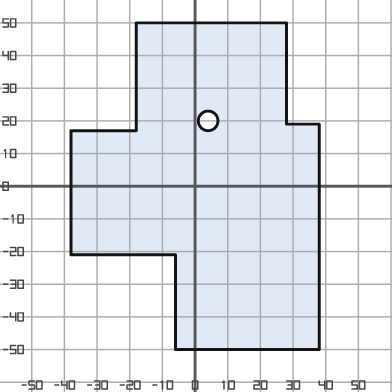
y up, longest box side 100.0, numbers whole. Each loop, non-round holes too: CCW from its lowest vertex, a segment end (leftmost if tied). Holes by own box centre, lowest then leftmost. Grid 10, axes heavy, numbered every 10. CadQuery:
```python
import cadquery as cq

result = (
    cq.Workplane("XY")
    .moveTo(-6.0, -50.0)
    .lineTo(38.0, -50.0)
    .lineTo(38.0, 19.0)
    .lineTo(28.0, 19.0)
    .lineTo(28.0, 50.0)
    .lineTo(-18.0, 50.0)
    .lineTo(-18.0, 17.0)
    .lineTo(-38.0, 17.0)
    .lineTo(-38.0, -21.0)
    .lineTo(-6.0, -21.0)
    .close()
    .moveTo(4.0, 20.0)
    .circle(3.0)
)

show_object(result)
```